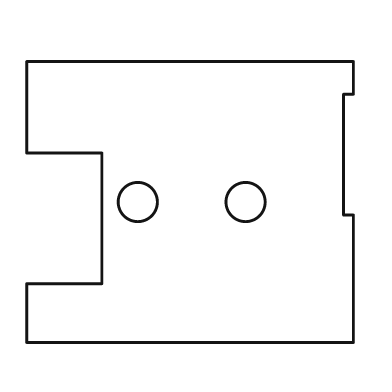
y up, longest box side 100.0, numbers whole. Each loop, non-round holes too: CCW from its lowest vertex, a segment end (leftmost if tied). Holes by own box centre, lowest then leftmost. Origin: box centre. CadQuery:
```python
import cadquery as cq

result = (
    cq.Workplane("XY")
    .moveTo(-50.0, -43.0)
    .lineTo(50.0, -43.0)
    .lineTo(50.0, -4.0)
    .lineTo(47.0, -4.0)
    .lineTo(47.0, 33.0)
    .lineTo(50.0, 33.0)
    .lineTo(50.0, 43.0)
    .lineTo(-50.0, 43.0)
    .lineTo(-50.0, 15.0)
    .lineTo(-27.0, 15.0)
    .lineTo(-27.0, -25.0)
    .lineTo(-50.0, -25.0)
    .close()
    .moveTo(-16.0, 0.0)
    .circle(6.0)
    .moveTo(17.0, 0.0)
    .circle(6.0)
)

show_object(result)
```